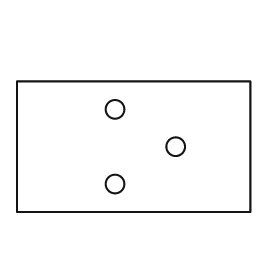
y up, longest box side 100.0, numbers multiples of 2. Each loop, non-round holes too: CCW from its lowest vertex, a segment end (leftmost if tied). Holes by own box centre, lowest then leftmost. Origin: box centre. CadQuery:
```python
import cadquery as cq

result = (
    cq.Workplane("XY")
    .moveTo(-50.0, -28.0)
    .lineTo(50.0, -28.0)
    .lineTo(50.0, 28.0)
    .lineTo(-50.0, 28.0)
    .close()
    .moveTo(-8.0, -16.0)
    .circle(4.0)
    .moveTo(18.0, 0.0)
    .circle(4.0)
    .moveTo(-8.0, 16.0)
    .circle(4.0)
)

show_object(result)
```